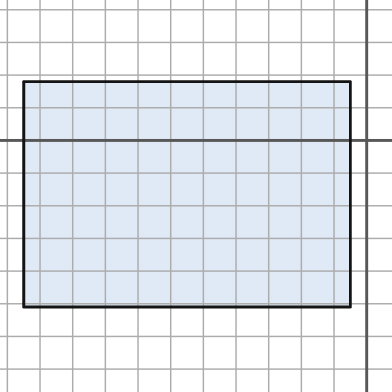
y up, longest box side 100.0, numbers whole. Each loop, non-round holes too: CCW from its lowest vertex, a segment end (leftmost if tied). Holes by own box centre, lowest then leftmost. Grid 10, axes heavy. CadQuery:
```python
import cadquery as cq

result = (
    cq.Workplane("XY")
    .moveTo(-105.0, -51.0)
    .lineTo(-5.0, -51.0)
    .lineTo(-5.0, 18.0)
    .lineTo(-105.0, 18.0)
    .close()
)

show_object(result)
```